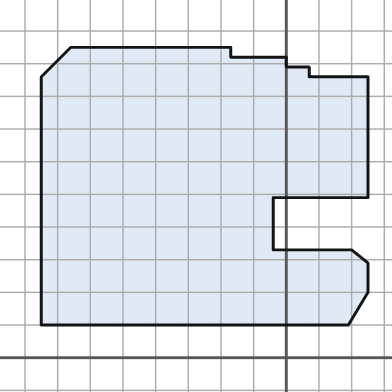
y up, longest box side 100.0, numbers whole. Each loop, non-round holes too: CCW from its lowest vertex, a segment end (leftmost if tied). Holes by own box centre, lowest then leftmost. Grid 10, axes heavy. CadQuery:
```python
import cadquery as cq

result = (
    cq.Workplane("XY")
    .moveTo(-75.0, 10.0)
    .lineTo(19.0, 10.0)
    .lineTo(25.0, 20.0)
    .lineTo(25.0, 29.0)
    .lineTo(20.0, 33.0)
    .lineTo(-4.0, 33.0)
    .lineTo(-4.0, 49.0)
    .lineTo(25.0, 49.0)
    .lineTo(25.0, 86.0)
    .lineTo(7.0, 86.0)
    .lineTo(7.0, 89.0)
    .lineTo(0.0, 89.0)
    .lineTo(0.0, 92.0)
    .lineTo(-17.0, 92.0)
    .lineTo(-17.0, 95.0)
    .lineTo(-66.0, 95.0)
    .lineTo(-75.0, 86.0)
    .close()
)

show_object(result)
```